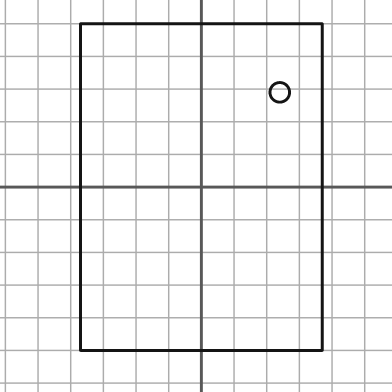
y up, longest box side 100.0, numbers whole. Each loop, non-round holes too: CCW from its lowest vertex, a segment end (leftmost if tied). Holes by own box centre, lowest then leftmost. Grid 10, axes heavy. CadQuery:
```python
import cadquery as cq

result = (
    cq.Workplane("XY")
    .moveTo(-37.0, -50.0)
    .lineTo(37.0, -50.0)
    .lineTo(37.0, 50.0)
    .lineTo(-37.0, 50.0)
    .close()
    .moveTo(24.0, 29.0)
    .circle(3.0)
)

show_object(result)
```